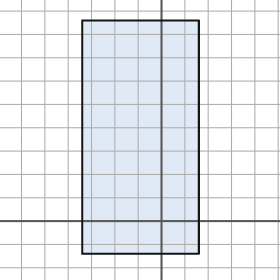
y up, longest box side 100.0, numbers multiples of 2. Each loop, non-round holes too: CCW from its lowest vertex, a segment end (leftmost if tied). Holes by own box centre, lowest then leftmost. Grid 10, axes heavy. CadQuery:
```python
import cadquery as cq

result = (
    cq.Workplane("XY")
    .moveTo(-34.0, -14.0)
    .lineTo(16.0, -14.0)
    .lineTo(16.0, 86.0)
    .lineTo(-34.0, 86.0)
    .close()
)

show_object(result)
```